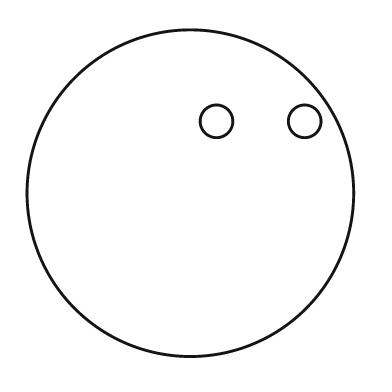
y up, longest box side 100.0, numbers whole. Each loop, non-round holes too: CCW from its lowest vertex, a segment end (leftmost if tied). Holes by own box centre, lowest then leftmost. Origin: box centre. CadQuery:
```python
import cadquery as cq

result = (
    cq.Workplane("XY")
    .moveTo(0.0, 0.0)
    .circle(50.0)
    .moveTo(8.0, 22.0)
    .circle(5.0)
    .moveTo(35.0, 22.0)
    .circle(5.0)
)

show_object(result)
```